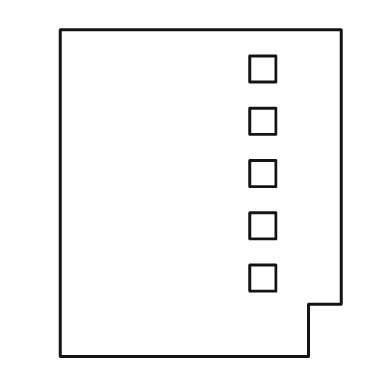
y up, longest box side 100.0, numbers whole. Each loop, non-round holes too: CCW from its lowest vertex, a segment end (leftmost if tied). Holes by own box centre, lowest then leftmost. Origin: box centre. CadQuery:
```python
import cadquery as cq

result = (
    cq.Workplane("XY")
    .moveTo(-43.0, -50.0)
    .lineTo(33.0, -50.0)
    .lineTo(33.0, -34.0)
    .lineTo(43.0, -34.0)
    .lineTo(43.0, 50.0)
    .lineTo(-43.0, 50.0)
    .close()
    .moveTo(15.0, -30.0)
    .lineTo(23.0, -30.0)
    .lineTo(23.0, -22.0)
    .lineTo(15.0, -22.0)
    .close()
    .moveTo(15.0, -14.0)
    .lineTo(23.0, -14.0)
    .lineTo(23.0, -6.0)
    .lineTo(15.0, -6.0)
    .close()
    .moveTo(15.0, 2.0)
    .lineTo(23.0, 2.0)
    .lineTo(23.0, 10.0)
    .lineTo(15.0, 10.0)
    .close()
    .moveTo(15.0, 18.0)
    .lineTo(23.0, 18.0)
    .lineTo(23.0, 26.0)
    .lineTo(15.0, 26.0)
    .close()
    .moveTo(15.0, 34.0)
    .lineTo(23.0, 34.0)
    .lineTo(23.0, 42.0)
    .lineTo(15.0, 42.0)
    .close()
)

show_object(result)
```